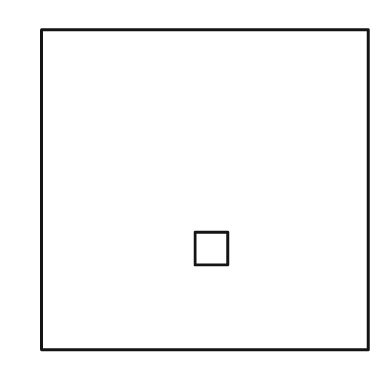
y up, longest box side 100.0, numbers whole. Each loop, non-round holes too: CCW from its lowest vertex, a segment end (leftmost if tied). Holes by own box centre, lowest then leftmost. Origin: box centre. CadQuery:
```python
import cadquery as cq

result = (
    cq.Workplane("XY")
    .moveTo(-50.0, -49.0)
    .lineTo(50.0, -49.0)
    .lineTo(50.0, 49.0)
    .lineTo(-50.0, 49.0)
    .close()
    .moveTo(-3.0, -23.0)
    .lineTo(7.0, -23.0)
    .lineTo(7.0, -13.0)
    .lineTo(-3.0, -13.0)
    .close()
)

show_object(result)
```